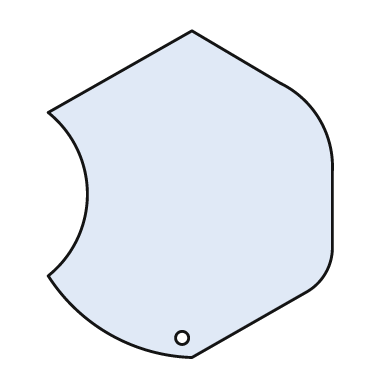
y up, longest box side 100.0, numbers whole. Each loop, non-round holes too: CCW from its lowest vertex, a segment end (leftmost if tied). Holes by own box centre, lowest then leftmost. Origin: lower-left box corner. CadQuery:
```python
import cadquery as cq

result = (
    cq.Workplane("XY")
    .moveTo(44.0, 0.0)
    .lineTo(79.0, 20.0)
    .threePointArc((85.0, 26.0), (87.0, 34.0))
    .lineTo(87.0, 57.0)
    .threePointArc((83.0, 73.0), (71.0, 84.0))
    .lineTo(44.0, 100.0)
    .lineTo(0.0, 75.0)
    .threePointArc((12.0, 50.0), (0.0, 25.0))
    .threePointArc((19.0, 7.0), (44.0, 0.0))
    .close()
    .moveTo(41.0, 6.0)
    .circle(2.0)
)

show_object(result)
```